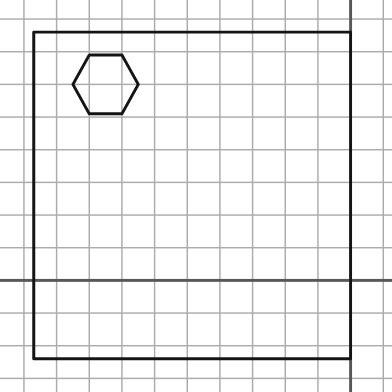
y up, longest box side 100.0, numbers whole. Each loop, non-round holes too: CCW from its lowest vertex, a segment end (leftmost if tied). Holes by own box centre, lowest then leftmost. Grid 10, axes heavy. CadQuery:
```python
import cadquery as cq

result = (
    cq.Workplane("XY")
    .moveTo(-97.0, -24.0)
    .lineTo(0.0, -24.0)
    .lineTo(0.0, 76.0)
    .lineTo(-97.0, 76.0)
    .close()
    .moveTo(-80.0, 51.0)
    .lineTo(-70.0, 51.0)
    .lineTo(-65.0, 60.0)
    .lineTo(-70.0, 69.0)
    .lineTo(-80.0, 69.0)
    .lineTo(-85.0, 60.0)
    .close()
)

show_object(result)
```